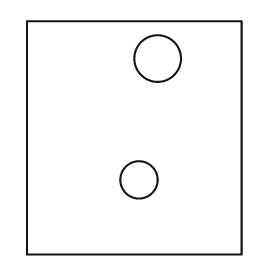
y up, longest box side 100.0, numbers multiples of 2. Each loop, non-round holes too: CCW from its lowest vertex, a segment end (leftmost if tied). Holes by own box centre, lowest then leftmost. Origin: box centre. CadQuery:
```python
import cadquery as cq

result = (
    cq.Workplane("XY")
    .moveTo(-46.0, -50.0)
    .lineTo(46.0, -50.0)
    .lineTo(46.0, 50.0)
    .lineTo(-46.0, 50.0)
    .close()
    .moveTo(2.0, -18.0)
    .circle(8.0)
    .moveTo(10.0, 34.0)
    .circle(10.0)
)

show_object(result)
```